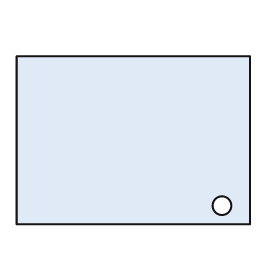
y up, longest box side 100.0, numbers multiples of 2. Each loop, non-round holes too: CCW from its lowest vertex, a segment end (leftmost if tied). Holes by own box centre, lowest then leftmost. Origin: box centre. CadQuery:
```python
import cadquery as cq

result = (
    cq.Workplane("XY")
    .moveTo(-50.0, -36.0)
    .lineTo(50.0, -36.0)
    .lineTo(50.0, 36.0)
    .lineTo(-50.0, 36.0)
    .close()
    .moveTo(38.0, -28.0)
    .circle(4.0)
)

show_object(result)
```